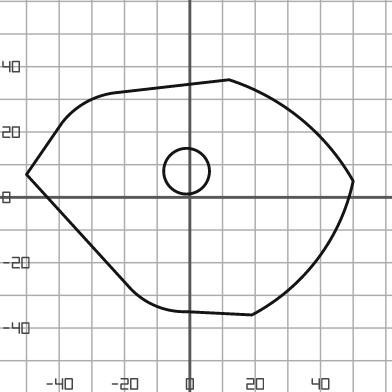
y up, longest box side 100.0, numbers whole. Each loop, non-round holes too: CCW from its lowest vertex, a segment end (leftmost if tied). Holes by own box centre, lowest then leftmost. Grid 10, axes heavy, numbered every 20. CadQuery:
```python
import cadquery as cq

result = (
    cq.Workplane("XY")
    .moveTo(19.0, -36.0)
    .threePointArc((39.0, -19.0), (50.0, 5.0))
    .threePointArc((34.0, 24.0), (12.0, 36.0))
    .lineTo(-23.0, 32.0)
    .threePointArc((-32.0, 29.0), (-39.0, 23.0))
    .lineTo(-50.0, 7.0)
    .lineTo(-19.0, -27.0)
    .threePointArc((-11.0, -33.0), (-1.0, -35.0))
    .close()
    .moveTo(-1.0, 8.0)
    .circle(7.0)
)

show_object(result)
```